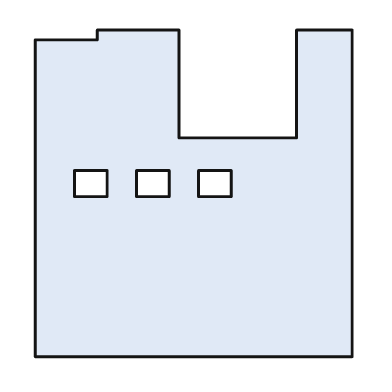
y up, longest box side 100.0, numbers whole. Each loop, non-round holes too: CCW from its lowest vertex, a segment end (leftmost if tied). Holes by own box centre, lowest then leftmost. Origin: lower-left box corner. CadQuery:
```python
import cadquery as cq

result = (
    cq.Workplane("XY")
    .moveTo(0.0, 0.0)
    .lineTo(97.0, 0.0)
    .lineTo(97.0, 100.0)
    .lineTo(80.0, 100.0)
    .lineTo(80.0, 67.0)
    .lineTo(44.0, 67.0)
    .lineTo(44.0, 100.0)
    .lineTo(19.0, 100.0)
    .lineTo(19.0, 97.0)
    .lineTo(0.0, 97.0)
    .close()
    .moveTo(12.0, 49.0)
    .lineTo(22.0, 49.0)
    .lineTo(22.0, 57.0)
    .lineTo(12.0, 57.0)
    .close()
    .moveTo(31.0, 49.0)
    .lineTo(41.0, 49.0)
    .lineTo(41.0, 57.0)
    .lineTo(31.0, 57.0)
    .close()
    .moveTo(50.0, 49.0)
    .lineTo(60.0, 49.0)
    .lineTo(60.0, 57.0)
    .lineTo(50.0, 57.0)
    .close()
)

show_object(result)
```